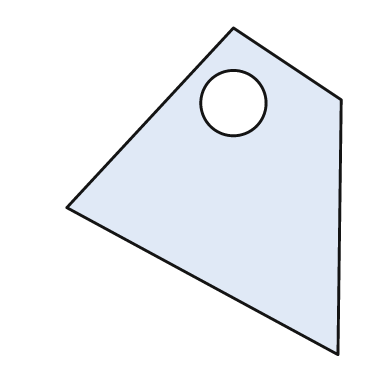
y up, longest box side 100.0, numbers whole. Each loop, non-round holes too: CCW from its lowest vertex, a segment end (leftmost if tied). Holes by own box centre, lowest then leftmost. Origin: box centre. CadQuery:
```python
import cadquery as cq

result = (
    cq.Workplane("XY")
    .moveTo(41.0, -50.0)
    .lineTo(42.0, 28.0)
    .lineTo(9.0, 50.0)
    .lineTo(-42.0, -5.0)
    .close()
    .moveTo(9.0, 27.0)
    .circle(10.0)
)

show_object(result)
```